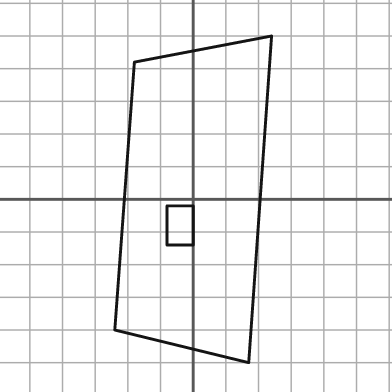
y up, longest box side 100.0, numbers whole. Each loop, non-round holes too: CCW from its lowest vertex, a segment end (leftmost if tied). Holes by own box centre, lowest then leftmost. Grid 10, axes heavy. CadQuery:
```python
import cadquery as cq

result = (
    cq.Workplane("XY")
    .moveTo(17.0, -50.0)
    .lineTo(24.0, 50.0)
    .lineTo(-18.0, 42.0)
    .lineTo(-24.0, -40.0)
    .close()
    .moveTo(-8.0, -14.0)
    .lineTo(0.0, -14.0)
    .lineTo(0.0, -2.0)
    .lineTo(-8.0, -2.0)
    .close()
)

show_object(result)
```